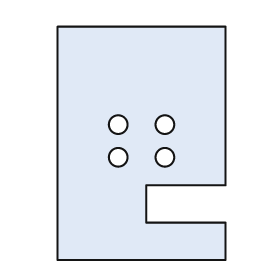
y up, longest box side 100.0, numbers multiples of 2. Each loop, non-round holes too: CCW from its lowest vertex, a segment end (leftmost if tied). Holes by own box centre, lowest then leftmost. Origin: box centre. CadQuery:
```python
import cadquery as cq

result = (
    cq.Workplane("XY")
    .moveTo(-36.0, -50.0)
    .lineTo(36.0, -50.0)
    .lineTo(36.0, -34.0)
    .lineTo(2.0, -34.0)
    .lineTo(2.0, -18.0)
    .lineTo(36.0, -18.0)
    .lineTo(36.0, 50.0)
    .lineTo(-36.0, 50.0)
    .close()
    .moveTo(-10.0, -6.0)
    .circle(4.0)
    .moveTo(10.0, -6.0)
    .circle(4.0)
    .moveTo(-10.0, 8.0)
    .circle(4.0)
    .moveTo(10.0, 8.0)
    .circle(4.0)
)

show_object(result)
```